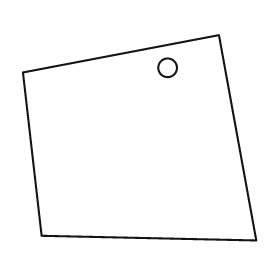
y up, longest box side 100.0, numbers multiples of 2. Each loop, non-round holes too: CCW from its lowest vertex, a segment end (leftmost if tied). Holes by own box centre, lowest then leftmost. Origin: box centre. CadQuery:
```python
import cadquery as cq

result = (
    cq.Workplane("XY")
    .moveTo(50.0, -44.0)
    .lineTo(34.0, 44.0)
    .lineTo(-50.0, 28.0)
    .lineTo(-42.0, -42.0)
    .close()
    .moveTo(12.0, 30.0)
    .circle(4.0)
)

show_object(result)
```